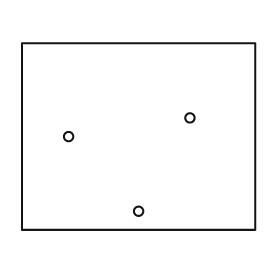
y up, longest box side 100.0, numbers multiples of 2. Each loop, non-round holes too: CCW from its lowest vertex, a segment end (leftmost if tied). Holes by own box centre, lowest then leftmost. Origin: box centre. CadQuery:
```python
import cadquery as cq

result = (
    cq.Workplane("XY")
    .moveTo(-50.0, -40.0)
    .lineTo(50.0, -40.0)
    .lineTo(50.0, 40.0)
    .lineTo(-50.0, 40.0)
    .close()
    .moveTo(0.0, -32.0)
    .circle(2.0)
    .moveTo(-30.0, 0.0)
    .circle(2.0)
    .moveTo(22.0, 8.0)
    .circle(2.0)
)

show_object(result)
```